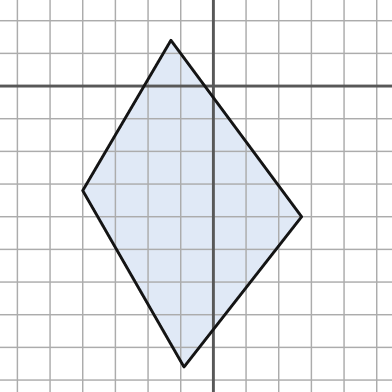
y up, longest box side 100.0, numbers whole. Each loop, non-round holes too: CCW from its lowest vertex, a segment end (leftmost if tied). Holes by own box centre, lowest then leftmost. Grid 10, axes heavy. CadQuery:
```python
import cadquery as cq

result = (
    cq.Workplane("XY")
    .moveTo(-9.0, -86.0)
    .lineTo(27.0, -40.0)
    .lineTo(-13.0, 14.0)
    .lineTo(-40.0, -32.0)
    .close()
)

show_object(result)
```